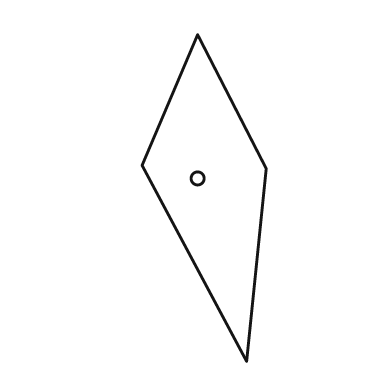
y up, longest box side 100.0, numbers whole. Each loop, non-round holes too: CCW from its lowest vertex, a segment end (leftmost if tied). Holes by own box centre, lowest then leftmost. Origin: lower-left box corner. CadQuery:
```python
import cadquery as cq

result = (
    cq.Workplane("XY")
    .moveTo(32.0, 0.0)
    .lineTo(38.0, 59.0)
    .lineTo(17.0, 100.0)
    .lineTo(0.0, 60.0)
    .close()
    .moveTo(17.0, 56.0)
    .circle(2.0)
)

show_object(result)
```